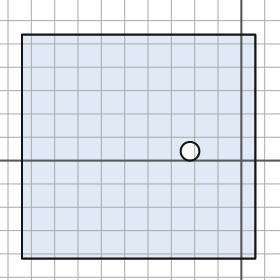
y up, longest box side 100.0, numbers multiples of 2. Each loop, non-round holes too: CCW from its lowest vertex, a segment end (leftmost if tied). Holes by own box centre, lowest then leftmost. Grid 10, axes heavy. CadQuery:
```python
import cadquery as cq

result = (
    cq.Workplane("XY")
    .moveTo(-94.0, -42.0)
    .lineTo(6.0, -42.0)
    .lineTo(6.0, 54.0)
    .lineTo(-94.0, 54.0)
    .close()
    .moveTo(-22.0, 4.0)
    .circle(4.0)
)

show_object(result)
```